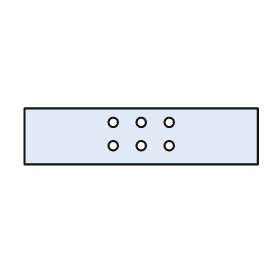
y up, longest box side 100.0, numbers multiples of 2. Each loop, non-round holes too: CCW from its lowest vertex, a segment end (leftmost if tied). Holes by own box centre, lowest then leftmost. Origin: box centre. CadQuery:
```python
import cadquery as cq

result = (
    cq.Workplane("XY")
    .moveTo(-50.0, -12.0)
    .lineTo(50.0, -12.0)
    .lineTo(50.0, 12.0)
    .lineTo(-50.0, 12.0)
    .close()
    .moveTo(-12.0, -4.0)
    .circle(2.0)
    .moveTo(0.0, -4.0)
    .circle(2.0)
    .moveTo(12.0, -4.0)
    .circle(2.0)
    .moveTo(-12.0, 6.0)
    .circle(2.0)
    .moveTo(0.0, 6.0)
    .circle(2.0)
    .moveTo(12.0, 6.0)
    .circle(2.0)
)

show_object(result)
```